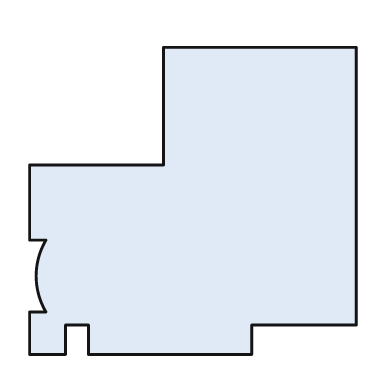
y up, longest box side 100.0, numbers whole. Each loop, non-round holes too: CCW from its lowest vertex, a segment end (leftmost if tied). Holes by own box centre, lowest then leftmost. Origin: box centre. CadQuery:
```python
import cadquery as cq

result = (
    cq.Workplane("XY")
    .moveTo(-50.0, -47.0)
    .lineTo(-39.0, -47.0)
    .lineTo(-39.0, -38.0)
    .lineTo(-32.0, -38.0)
    .lineTo(-32.0, -47.0)
    .lineTo(18.0, -47.0)
    .lineTo(18.0, -38.0)
    .lineTo(50.0, -38.0)
    .lineTo(50.0, 47.0)
    .lineTo(-9.0, 47.0)
    .lineTo(-9.0, 11.0)
    .lineTo(-50.0, 11.0)
    .lineTo(-50.0, -12.0)
    .lineTo(-45.0, -12.0)
    .threePointArc((-48.0, -23.0), (-45.0, -34.0))
    .lineTo(-50.0, -34.0)
    .close()
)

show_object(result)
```